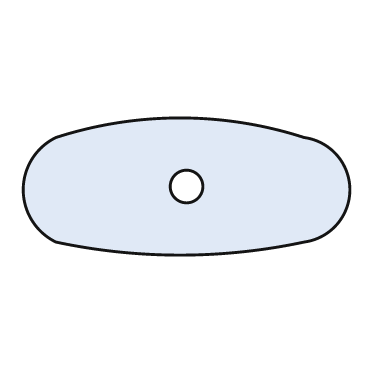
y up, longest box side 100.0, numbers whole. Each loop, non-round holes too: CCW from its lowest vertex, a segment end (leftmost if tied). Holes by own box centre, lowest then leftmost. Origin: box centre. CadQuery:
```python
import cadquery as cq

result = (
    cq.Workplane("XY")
    .moveTo(-40.0, -17.0)
    .threePointArc((-2.0, -21.0), (36.0, -17.0))
    .threePointArc((50.0, -1.0), (36.0, 15.0))
    .threePointArc((-2.0, 21.0), (-40.0, 15.0))
    .threePointArc((-50.0, -1.0), (-40.0, -17.0))
    .close()
    .moveTo(0.0, 0.0)
    .circle(5.0)
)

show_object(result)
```